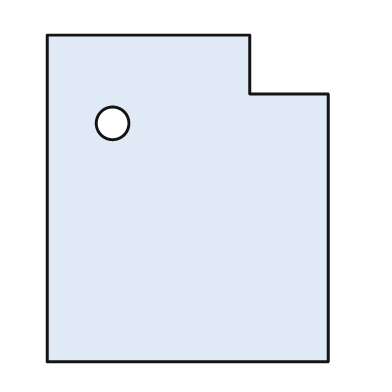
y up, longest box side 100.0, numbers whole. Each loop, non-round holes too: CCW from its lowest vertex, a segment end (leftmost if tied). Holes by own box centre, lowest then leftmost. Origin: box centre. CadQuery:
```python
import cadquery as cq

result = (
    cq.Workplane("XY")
    .moveTo(-43.0, -50.0)
    .lineTo(43.0, -50.0)
    .lineTo(43.0, 32.0)
    .lineTo(19.0, 32.0)
    .lineTo(19.0, 50.0)
    .lineTo(-43.0, 50.0)
    .close()
    .moveTo(-23.0, 23.0)
    .circle(5.0)
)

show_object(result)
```